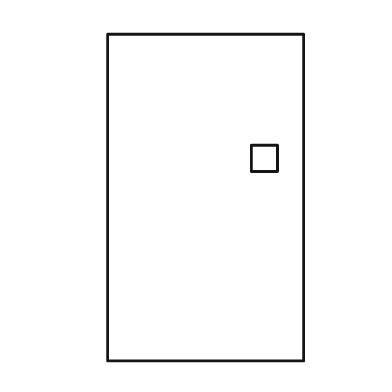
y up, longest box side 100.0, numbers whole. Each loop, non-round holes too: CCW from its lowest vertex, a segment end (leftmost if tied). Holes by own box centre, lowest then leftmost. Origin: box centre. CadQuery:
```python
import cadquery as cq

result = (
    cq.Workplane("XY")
    .moveTo(-30.0, -50.0)
    .lineTo(30.0, -50.0)
    .lineTo(30.0, 50.0)
    .lineTo(-30.0, 50.0)
    .close()
    .moveTo(14.0, 8.0)
    .lineTo(22.0, 8.0)
    .lineTo(22.0, 16.0)
    .lineTo(14.0, 16.0)
    .close()
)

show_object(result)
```